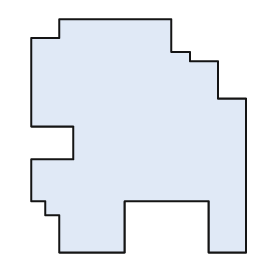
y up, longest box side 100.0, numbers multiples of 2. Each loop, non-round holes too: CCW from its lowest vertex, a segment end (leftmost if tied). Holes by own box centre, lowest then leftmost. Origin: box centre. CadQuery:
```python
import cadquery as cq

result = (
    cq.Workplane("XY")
    .moveTo(-34.0, -50.0)
    .lineTo(-6.0, -50.0)
    .lineTo(-6.0, -28.0)
    .lineTo(30.0, -28.0)
    .lineTo(30.0, -50.0)
    .lineTo(46.0, -50.0)
    .lineTo(46.0, 16.0)
    .lineTo(34.0, 16.0)
    .lineTo(34.0, 32.0)
    .lineTo(22.0, 32.0)
    .lineTo(22.0, 36.0)
    .lineTo(14.0, 36.0)
    .lineTo(14.0, 50.0)
    .lineTo(-34.0, 50.0)
    .lineTo(-34.0, 42.0)
    .lineTo(-46.0, 42.0)
    .lineTo(-46.0, 4.0)
    .lineTo(-28.0, 4.0)
    .lineTo(-28.0, -10.0)
    .lineTo(-46.0, -10.0)
    .lineTo(-46.0, -28.0)
    .lineTo(-40.0, -28.0)
    .lineTo(-40.0, -34.0)
    .lineTo(-34.0, -34.0)
    .close()
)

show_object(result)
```